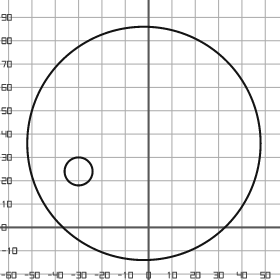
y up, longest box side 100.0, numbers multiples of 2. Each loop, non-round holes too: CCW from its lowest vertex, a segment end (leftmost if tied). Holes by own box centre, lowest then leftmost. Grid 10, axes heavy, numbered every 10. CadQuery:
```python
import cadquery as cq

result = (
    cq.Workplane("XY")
    .moveTo(-2.0, 36.0)
    .circle(50.0)
    .moveTo(-30.0, 24.0)
    .circle(6.0)
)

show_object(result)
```